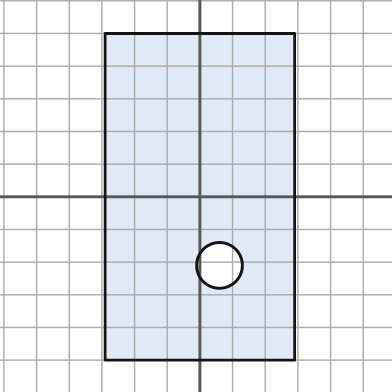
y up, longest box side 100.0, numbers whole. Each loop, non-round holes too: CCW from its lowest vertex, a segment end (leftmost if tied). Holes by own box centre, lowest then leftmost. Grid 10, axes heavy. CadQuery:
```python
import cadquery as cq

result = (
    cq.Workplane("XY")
    .moveTo(-29.0, -50.0)
    .lineTo(29.0, -50.0)
    .lineTo(29.0, 50.0)
    .lineTo(-29.0, 50.0)
    .close()
    .moveTo(6.0, -21.0)
    .circle(7.0)
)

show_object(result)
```